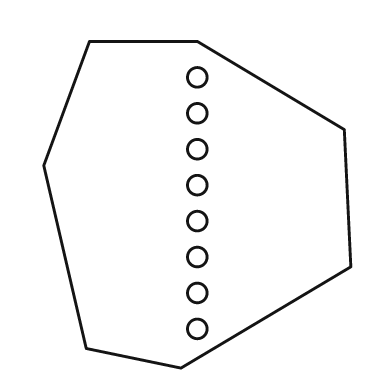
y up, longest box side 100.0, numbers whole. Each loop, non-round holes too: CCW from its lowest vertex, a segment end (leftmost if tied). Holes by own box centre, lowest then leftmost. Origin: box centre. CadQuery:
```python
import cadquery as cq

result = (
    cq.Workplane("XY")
    .moveTo(-5.0, -50.0)
    .lineTo(47.0, -19.0)
    .lineTo(45.0, 23.0)
    .lineTo(0.0, 50.0)
    .lineTo(-33.0, 50.0)
    .lineTo(-47.0, 12.0)
    .lineTo(-34.0, -44.0)
    .close()
    .moveTo(0.0, -38.0)
    .circle(3.0)
    .moveTo(0.0, -27.0)
    .circle(3.0)
    .moveTo(0.0, -16.0)
    .circle(3.0)
    .moveTo(0.0, -5.0)
    .circle(3.0)
    .moveTo(0.0, 6.0)
    .circle(3.0)
    .moveTo(0.0, 17.0)
    .circle(3.0)
    .moveTo(0.0, 28.0)
    .circle(3.0)
    .moveTo(0.0, 39.0)
    .circle(3.0)
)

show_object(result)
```